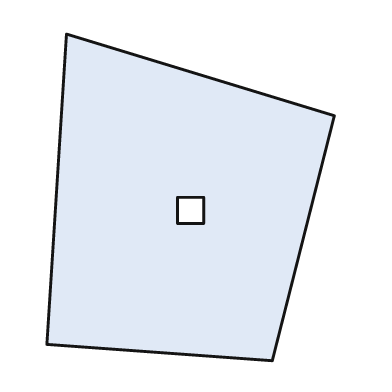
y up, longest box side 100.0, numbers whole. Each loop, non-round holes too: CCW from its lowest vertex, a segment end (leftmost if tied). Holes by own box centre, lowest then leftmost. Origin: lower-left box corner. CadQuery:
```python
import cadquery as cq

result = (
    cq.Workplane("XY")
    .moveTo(69.0, 0.0)
    .lineTo(88.0, 75.0)
    .lineTo(6.0, 100.0)
    .lineTo(0.0, 5.0)
    .close()
    .moveTo(40.0, 42.0)
    .lineTo(48.0, 42.0)
    .lineTo(48.0, 50.0)
    .lineTo(40.0, 50.0)
    .close()
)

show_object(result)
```